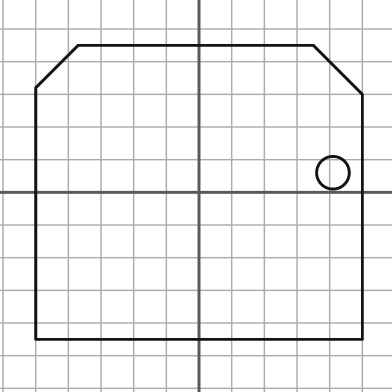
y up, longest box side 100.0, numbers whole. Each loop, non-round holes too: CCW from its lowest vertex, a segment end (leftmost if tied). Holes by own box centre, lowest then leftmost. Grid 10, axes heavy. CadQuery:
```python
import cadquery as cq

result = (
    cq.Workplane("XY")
    .moveTo(-50.0, -45.0)
    .lineTo(50.0, -45.0)
    .lineTo(50.0, 30.0)
    .lineTo(35.0, 45.0)
    .lineTo(-37.0, 45.0)
    .lineTo(-50.0, 32.0)
    .close()
    .moveTo(41.0, 6.0)
    .circle(5.0)
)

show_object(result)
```